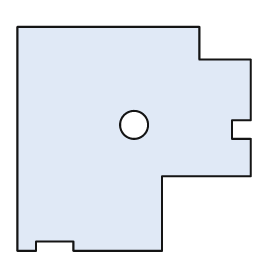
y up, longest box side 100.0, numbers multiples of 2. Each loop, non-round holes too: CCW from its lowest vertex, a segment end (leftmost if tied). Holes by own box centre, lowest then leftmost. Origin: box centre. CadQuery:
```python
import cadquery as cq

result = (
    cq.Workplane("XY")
    .moveTo(-50.0, -48.0)
    .lineTo(-42.0, -48.0)
    .lineTo(-42.0, -44.0)
    .lineTo(-26.0, -44.0)
    .lineTo(-26.0, -48.0)
    .lineTo(12.0, -48.0)
    .lineTo(12.0, -16.0)
    .lineTo(50.0, -16.0)
    .lineTo(50.0, 0.0)
    .lineTo(42.0, 0.0)
    .lineTo(42.0, 8.0)
    .lineTo(50.0, 8.0)
    .lineTo(50.0, 34.0)
    .lineTo(28.0, 34.0)
    .lineTo(28.0, 48.0)
    .lineTo(-50.0, 48.0)
    .close()
    .moveTo(0.0, 6.0)
    .circle(6.0)
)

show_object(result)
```